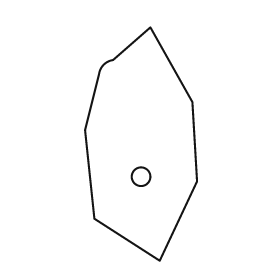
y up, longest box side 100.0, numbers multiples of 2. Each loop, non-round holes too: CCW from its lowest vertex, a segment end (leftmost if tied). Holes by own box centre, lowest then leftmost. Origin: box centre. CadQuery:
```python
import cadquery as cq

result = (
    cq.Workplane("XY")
    .moveTo(8.0, -50.0)
    .lineTo(24.0, -16.0)
    .lineTo(22.0, 18.0)
    .lineTo(4.0, 50.0)
    .lineTo(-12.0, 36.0)
    .threePointArc((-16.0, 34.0), (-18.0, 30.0))
    .lineTo(-24.0, 6.0)
    .lineTo(-20.0, -32.0)
    .close()
    .moveTo(0.0, -14.0)
    .circle(4.0)
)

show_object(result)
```